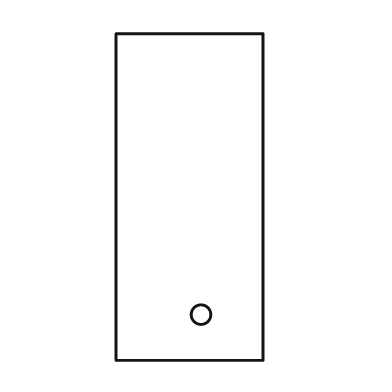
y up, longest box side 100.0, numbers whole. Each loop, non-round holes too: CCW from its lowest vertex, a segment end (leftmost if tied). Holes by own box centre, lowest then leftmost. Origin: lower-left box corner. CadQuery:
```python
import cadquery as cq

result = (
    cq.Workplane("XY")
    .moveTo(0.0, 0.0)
    .lineTo(45.0, 0.0)
    .lineTo(45.0, 100.0)
    .lineTo(0.0, 100.0)
    .close()
    .moveTo(26.0, 14.0)
    .circle(3.0)
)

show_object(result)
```